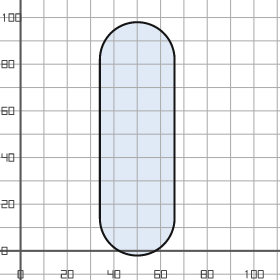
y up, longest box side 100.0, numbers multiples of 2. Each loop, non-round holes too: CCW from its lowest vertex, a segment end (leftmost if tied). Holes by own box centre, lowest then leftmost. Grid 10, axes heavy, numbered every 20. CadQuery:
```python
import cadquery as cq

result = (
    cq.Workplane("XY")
    .moveTo(34.0, 14.0)
    .threePointArc((50.0, -2.0), (66.0, 14.0))
    .lineTo(66.0, 82.0)
    .threePointArc((50.0, 98.0), (34.0, 82.0))
    .close()
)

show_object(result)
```